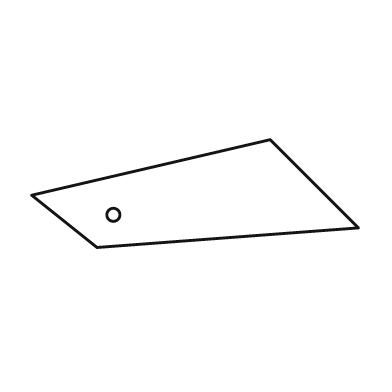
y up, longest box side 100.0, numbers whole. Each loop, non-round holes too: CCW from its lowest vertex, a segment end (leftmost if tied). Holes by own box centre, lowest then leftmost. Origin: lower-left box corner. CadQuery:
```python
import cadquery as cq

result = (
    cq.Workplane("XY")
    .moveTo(20.0, 0.0)
    .lineTo(100.0, 6.0)
    .lineTo(73.0, 33.0)
    .lineTo(0.0, 16.0)
    .close()
    .moveTo(25.0, 10.0)
    .circle(2.0)
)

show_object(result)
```